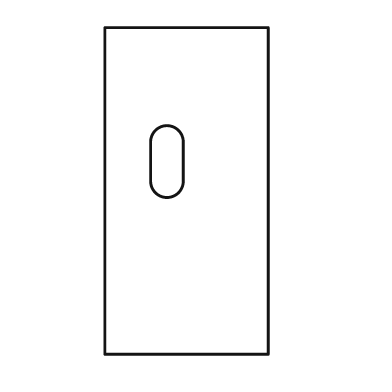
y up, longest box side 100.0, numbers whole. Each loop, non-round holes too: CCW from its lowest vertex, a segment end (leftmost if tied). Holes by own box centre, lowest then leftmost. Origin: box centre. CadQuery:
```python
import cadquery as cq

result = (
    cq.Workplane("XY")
    .moveTo(-25.0, -50.0)
    .lineTo(25.0, -50.0)
    .lineTo(25.0, 50.0)
    .lineTo(-25.0, 50.0)
    .close()
    .moveTo(-11.0, 3.0)
    .threePointArc((-6.0, -2.0), (-1.0, 3.0))
    .lineTo(-1.0, 15.0)
    .threePointArc((-6.0, 20.0), (-11.0, 15.0))
    .close()
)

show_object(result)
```